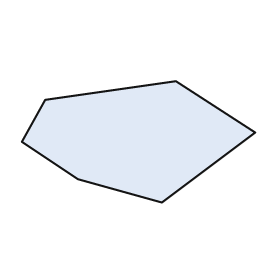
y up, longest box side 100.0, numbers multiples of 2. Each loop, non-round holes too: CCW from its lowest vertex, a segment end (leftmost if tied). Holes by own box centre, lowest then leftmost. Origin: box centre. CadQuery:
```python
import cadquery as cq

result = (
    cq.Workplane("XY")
    .moveTo(10.0, -26.0)
    .lineTo(50.0, 4.0)
    .lineTo(16.0, 26.0)
    .lineTo(-40.0, 18.0)
    .lineTo(-50.0, 0.0)
    .lineTo(-26.0, -16.0)
    .close()
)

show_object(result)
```